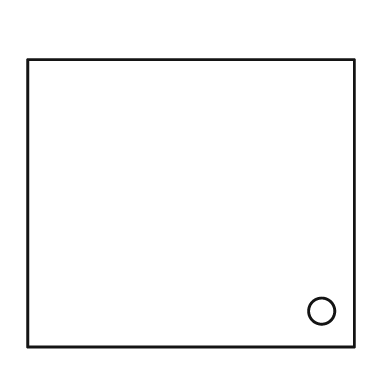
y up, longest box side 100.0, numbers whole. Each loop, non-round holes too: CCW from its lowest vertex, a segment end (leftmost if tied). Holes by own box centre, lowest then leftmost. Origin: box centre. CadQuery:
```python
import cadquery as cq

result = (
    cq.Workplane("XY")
    .moveTo(-50.0, -44.0)
    .lineTo(50.0, -44.0)
    .lineTo(50.0, 44.0)
    .lineTo(-50.0, 44.0)
    .close()
    .moveTo(40.0, -33.0)
    .circle(4.0)
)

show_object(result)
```